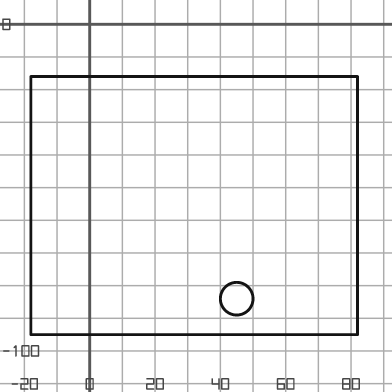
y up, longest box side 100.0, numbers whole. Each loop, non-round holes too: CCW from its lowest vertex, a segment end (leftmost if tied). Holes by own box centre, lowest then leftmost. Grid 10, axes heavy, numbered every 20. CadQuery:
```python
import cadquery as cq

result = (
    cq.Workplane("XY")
    .moveTo(-18.0, -95.0)
    .lineTo(82.0, -95.0)
    .lineTo(82.0, -16.0)
    .lineTo(-18.0, -16.0)
    .close()
    .moveTo(45.0, -84.0)
    .circle(5.0)
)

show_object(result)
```